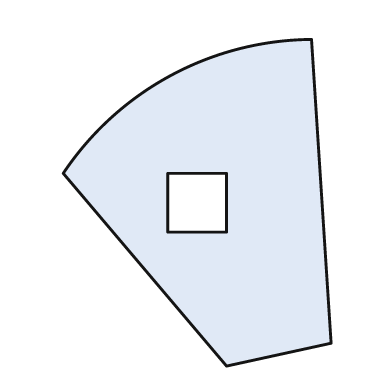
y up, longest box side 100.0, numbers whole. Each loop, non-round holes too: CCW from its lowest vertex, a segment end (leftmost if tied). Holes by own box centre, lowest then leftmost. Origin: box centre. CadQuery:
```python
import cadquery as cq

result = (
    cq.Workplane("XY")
    .moveTo(9.0, -50.0)
    .lineTo(41.0, -43.0)
    .lineTo(35.0, 50.0)
    .threePointArc((-8.0, 39.0), (-41.0, 9.0))
    .close()
    .moveTo(-9.0, -9.0)
    .lineTo(9.0, -9.0)
    .lineTo(9.0, 9.0)
    .lineTo(-9.0, 9.0)
    .close()
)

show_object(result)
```